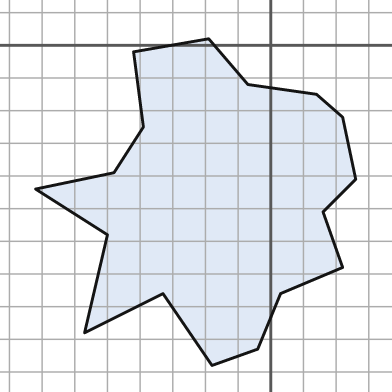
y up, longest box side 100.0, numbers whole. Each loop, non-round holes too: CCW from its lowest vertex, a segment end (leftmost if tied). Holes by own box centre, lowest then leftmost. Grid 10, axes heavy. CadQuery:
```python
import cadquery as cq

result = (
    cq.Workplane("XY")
    .moveTo(-18.0, -98.0)
    .lineTo(-4.0, -93.0)
    .lineTo(3.0, -76.0)
    .lineTo(22.0, -68.0)
    .lineTo(16.0, -51.0)
    .lineTo(26.0, -41.0)
    .lineTo(22.0, -22.0)
    .lineTo(14.0, -15.0)
    .lineTo(-7.0, -12.0)
    .lineTo(-19.0, 2.0)
    .lineTo(-42.0, -2.0)
    .lineTo(-39.0, -25.0)
    .lineTo(-48.0, -39.0)
    .lineTo(-72.0, -44.0)
    .lineTo(-50.0, -58.0)
    .lineTo(-57.0, -88.0)
    .lineTo(-33.0, -76.0)
    .close()
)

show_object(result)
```